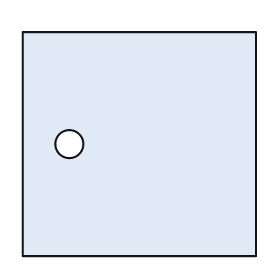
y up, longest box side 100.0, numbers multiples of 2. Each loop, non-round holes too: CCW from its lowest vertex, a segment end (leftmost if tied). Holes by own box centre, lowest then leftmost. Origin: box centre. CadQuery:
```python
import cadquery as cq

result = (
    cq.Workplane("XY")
    .moveTo(-50.0, -48.0)
    .lineTo(50.0, -48.0)
    .lineTo(50.0, 48.0)
    .lineTo(-50.0, 48.0)
    .close()
    .moveTo(-30.0, 0.0)
    .circle(6.0)
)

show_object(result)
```